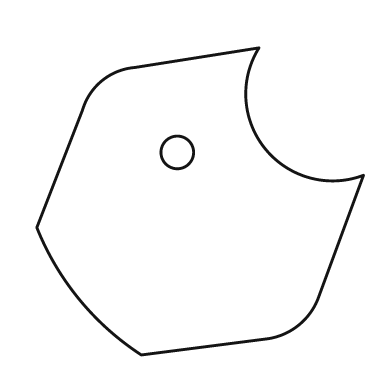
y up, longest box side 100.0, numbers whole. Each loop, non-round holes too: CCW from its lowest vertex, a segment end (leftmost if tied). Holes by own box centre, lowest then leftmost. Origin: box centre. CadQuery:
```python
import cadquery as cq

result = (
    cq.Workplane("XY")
    .moveTo(-18.0, -47.0)
    .lineTo(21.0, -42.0)
    .threePointArc((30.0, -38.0), (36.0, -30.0))
    .lineTo(50.0, 8.0)
    .threePointArc((20.0, 16.0), (18.0, 47.0))
    .lineTo(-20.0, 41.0)
    .threePointArc((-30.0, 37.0), (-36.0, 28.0))
    .lineTo(-50.0, -8.0)
    .threePointArc((-37.0, -30.0), (-18.0, -47.0))
    .close()
    .moveTo(-7.0, 15.0)
    .circle(5.0)
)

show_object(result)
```